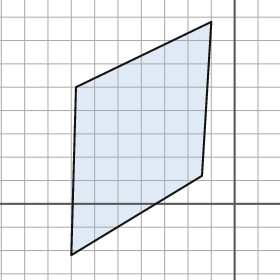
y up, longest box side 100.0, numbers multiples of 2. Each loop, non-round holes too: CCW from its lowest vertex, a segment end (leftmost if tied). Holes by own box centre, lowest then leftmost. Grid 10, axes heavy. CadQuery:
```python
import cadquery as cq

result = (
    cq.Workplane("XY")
    .moveTo(-70.0, -22.0)
    .lineTo(-14.0, 12.0)
    .lineTo(-10.0, 78.0)
    .lineTo(-68.0, 50.0)
    .close()
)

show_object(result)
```